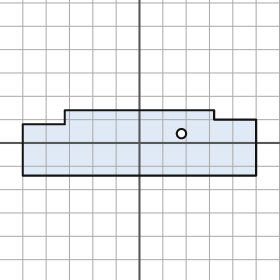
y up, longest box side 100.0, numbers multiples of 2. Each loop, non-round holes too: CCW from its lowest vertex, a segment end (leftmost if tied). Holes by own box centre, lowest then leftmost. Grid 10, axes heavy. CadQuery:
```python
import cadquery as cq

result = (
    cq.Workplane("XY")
    .moveTo(-50.0, -14.0)
    .lineTo(50.0, -14.0)
    .lineTo(50.0, 10.0)
    .lineTo(32.0, 10.0)
    .lineTo(32.0, 14.0)
    .lineTo(-32.0, 14.0)
    .lineTo(-32.0, 8.0)
    .lineTo(-50.0, 8.0)
    .close()
    .moveTo(18.0, 4.0)
    .circle(2.0)
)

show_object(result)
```